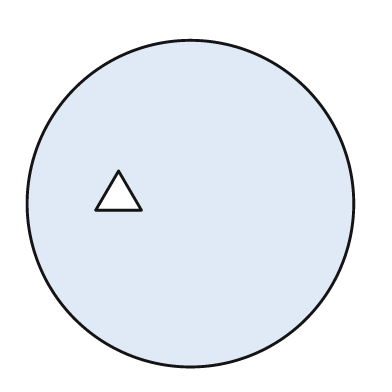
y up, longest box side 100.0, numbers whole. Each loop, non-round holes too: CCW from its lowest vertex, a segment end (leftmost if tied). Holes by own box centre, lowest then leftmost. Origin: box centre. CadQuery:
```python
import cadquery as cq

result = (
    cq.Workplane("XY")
    .moveTo(0.0, 0.0)
    .circle(50.0)
    .moveTo(-29.0, -2.0)
    .lineTo(-15.0, -2.0)
    .lineTo(-22.0, 10.0)
    .close()
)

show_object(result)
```